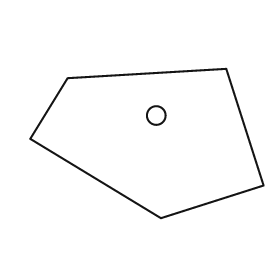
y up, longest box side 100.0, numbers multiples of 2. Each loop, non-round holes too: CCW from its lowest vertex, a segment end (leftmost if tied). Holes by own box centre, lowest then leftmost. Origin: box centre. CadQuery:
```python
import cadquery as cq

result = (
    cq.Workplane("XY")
    .moveTo(6.0, -32.0)
    .lineTo(50.0, -18.0)
    .lineTo(34.0, 32.0)
    .lineTo(-34.0, 28.0)
    .lineTo(-50.0, 2.0)
    .close()
    .moveTo(4.0, 12.0)
    .circle(4.0)
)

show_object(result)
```